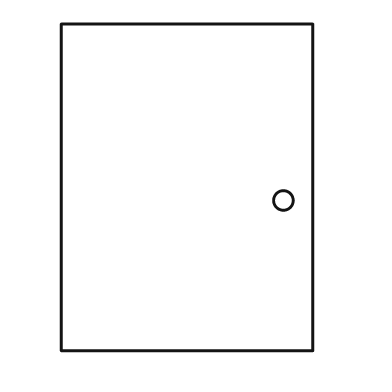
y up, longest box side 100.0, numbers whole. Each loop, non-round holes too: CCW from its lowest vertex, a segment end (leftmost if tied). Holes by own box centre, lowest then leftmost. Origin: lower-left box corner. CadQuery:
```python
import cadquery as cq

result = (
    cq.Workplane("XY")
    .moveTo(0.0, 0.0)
    .lineTo(77.0, 0.0)
    .lineTo(77.0, 100.0)
    .lineTo(0.0, 100.0)
    .close()
    .moveTo(68.0, 46.0)
    .circle(3.0)
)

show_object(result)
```